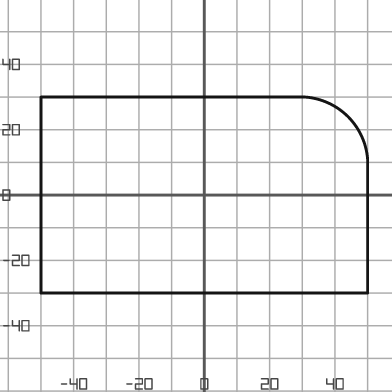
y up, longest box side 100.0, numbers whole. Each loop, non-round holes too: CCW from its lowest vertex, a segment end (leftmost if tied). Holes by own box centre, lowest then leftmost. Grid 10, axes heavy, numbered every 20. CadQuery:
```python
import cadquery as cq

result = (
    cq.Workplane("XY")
    .moveTo(-50.0, -30.0)
    .lineTo(50.0, -30.0)
    .lineTo(50.0, 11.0)
    .threePointArc((44.0, 24.0), (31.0, 30.0))
    .lineTo(-50.0, 30.0)
    .close()
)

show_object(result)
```